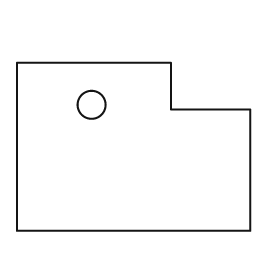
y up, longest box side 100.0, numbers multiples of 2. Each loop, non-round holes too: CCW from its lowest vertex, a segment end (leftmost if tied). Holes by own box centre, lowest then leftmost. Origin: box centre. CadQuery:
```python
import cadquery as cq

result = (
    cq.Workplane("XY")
    .moveTo(-50.0, -36.0)
    .lineTo(50.0, -36.0)
    .lineTo(50.0, 16.0)
    .lineTo(16.0, 16.0)
    .lineTo(16.0, 36.0)
    .lineTo(-50.0, 36.0)
    .close()
    .moveTo(-18.0, 18.0)
    .circle(6.0)
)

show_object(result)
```